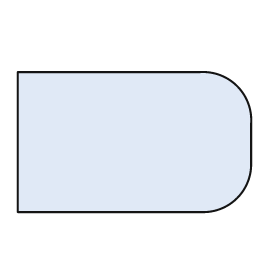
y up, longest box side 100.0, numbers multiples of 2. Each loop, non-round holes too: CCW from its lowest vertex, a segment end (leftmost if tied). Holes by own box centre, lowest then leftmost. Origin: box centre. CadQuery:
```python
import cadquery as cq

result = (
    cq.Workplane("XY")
    .moveTo(-50.0, -30.0)
    .lineTo(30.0, -30.0)
    .threePointArc((44.0, -24.0), (50.0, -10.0))
    .lineTo(50.0, 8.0)
    .threePointArc((44.0, 24.0), (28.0, 30.0))
    .lineTo(-50.0, 30.0)
    .close()
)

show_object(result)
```